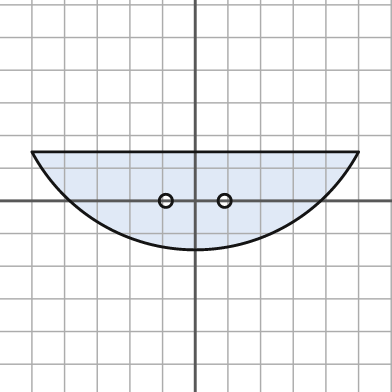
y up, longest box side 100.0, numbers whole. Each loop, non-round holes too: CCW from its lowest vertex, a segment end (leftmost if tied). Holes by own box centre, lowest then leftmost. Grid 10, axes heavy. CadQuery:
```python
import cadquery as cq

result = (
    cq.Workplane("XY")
    .moveTo(-50.0, 15.0)
    .threePointArc((0.0, -15.0), (50.0, 15.0))
    .close()
    .moveTo(-9.0, 0.0)
    .circle(2.0)
    .moveTo(9.0, 0.0)
    .circle(2.0)
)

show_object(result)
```